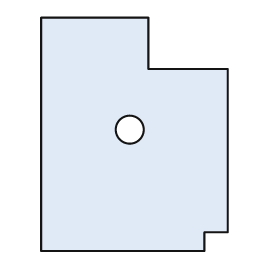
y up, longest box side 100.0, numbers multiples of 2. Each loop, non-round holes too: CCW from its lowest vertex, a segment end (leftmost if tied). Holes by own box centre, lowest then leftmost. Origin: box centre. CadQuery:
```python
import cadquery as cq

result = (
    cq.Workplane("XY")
    .moveTo(-40.0, -50.0)
    .lineTo(30.0, -50.0)
    .lineTo(30.0, -42.0)
    .lineTo(40.0, -42.0)
    .lineTo(40.0, 28.0)
    .lineTo(6.0, 28.0)
    .lineTo(6.0, 50.0)
    .lineTo(-40.0, 50.0)
    .close()
    .moveTo(-2.0, 2.0)
    .circle(6.0)
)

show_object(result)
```